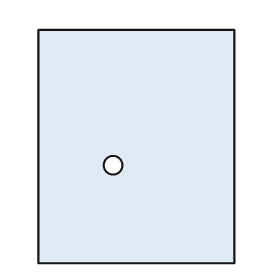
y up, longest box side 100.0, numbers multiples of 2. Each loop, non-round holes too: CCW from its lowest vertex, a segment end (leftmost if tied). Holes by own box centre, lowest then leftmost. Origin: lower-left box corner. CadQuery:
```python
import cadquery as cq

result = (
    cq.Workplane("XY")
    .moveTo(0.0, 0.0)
    .lineTo(84.0, 0.0)
    .lineTo(84.0, 100.0)
    .lineTo(0.0, 100.0)
    .close()
    .moveTo(32.0, 42.0)
    .circle(4.0)
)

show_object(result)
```